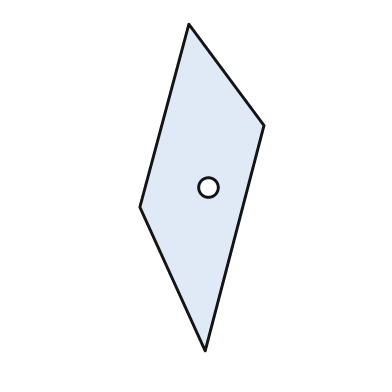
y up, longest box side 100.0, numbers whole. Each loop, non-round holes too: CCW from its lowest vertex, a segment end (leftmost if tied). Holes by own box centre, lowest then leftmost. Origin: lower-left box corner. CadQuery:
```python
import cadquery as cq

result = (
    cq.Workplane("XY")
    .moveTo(20.0, 0.0)
    .lineTo(38.0, 69.0)
    .lineTo(15.0, 100.0)
    .lineTo(0.0, 44.0)
    .close()
    .moveTo(21.0, 50.0)
    .circle(3.0)
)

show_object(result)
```